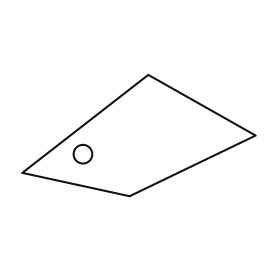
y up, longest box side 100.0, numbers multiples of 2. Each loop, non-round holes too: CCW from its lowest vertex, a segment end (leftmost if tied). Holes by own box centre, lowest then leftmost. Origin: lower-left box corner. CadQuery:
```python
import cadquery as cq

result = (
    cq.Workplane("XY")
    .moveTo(46.0, 0.0)
    .lineTo(100.0, 26.0)
    .lineTo(54.0, 52.0)
    .lineTo(0.0, 10.0)
    .close()
    .moveTo(26.0, 18.0)
    .circle(4.0)
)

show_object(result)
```